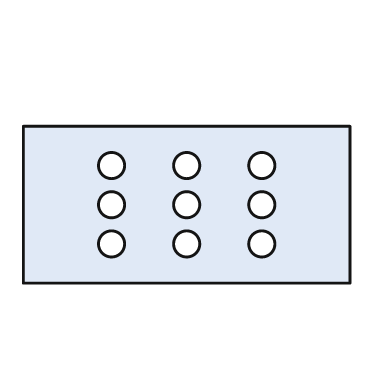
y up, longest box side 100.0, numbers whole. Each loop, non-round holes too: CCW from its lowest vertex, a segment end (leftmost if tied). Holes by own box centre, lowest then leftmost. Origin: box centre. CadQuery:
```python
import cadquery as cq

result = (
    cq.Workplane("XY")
    .moveTo(-50.0, -24.0)
    .lineTo(50.0, -24.0)
    .lineTo(50.0, 24.0)
    .lineTo(-50.0, 24.0)
    .close()
    .moveTo(-23.0, -12.0)
    .circle(4.0)
    .moveTo(0.0, -12.0)
    .circle(4.0)
    .moveTo(23.0, -12.0)
    .circle(4.0)
    .moveTo(-23.0, 0.0)
    .circle(4.0)
    .moveTo(0.0, 0.0)
    .circle(4.0)
    .moveTo(23.0, 0.0)
    .circle(4.0)
    .moveTo(-23.0, 12.0)
    .circle(4.0)
    .moveTo(0.0, 12.0)
    .circle(4.0)
    .moveTo(23.0, 12.0)
    .circle(4.0)
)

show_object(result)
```